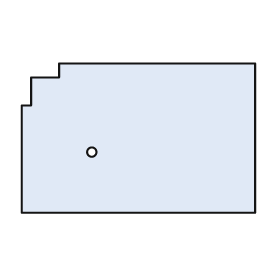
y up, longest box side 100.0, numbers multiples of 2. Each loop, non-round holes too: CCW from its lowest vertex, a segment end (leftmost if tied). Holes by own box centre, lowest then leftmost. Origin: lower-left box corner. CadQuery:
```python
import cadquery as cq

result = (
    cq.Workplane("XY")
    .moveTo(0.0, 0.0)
    .lineTo(100.0, 0.0)
    .lineTo(100.0, 64.0)
    .lineTo(16.0, 64.0)
    .lineTo(16.0, 58.0)
    .lineTo(4.0, 58.0)
    .lineTo(4.0, 46.0)
    .lineTo(0.0, 46.0)
    .close()
    .moveTo(30.0, 26.0)
    .circle(2.0)
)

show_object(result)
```